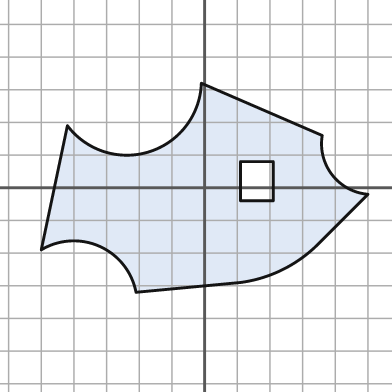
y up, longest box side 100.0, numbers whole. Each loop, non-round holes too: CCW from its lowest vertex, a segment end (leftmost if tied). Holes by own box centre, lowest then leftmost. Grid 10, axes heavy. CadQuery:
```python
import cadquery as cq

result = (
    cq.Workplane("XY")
    .moveTo(-21.0, -32.0)
    .lineTo(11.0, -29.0)
    .threePointArc((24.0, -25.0), (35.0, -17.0))
    .lineTo(50.0, -2.0)
    .threePointArc((39.0, 4.0), (36.0, 16.0))
    .lineTo(-1.0, 32.0)
    .threePointArc((-17.0, 11.0), (-42.0, 19.0))
    .lineTo(-50.0, -19.0)
    .threePointArc((-32.0, -18.0), (-21.0, -32.0))
    .close()
    .moveTo(11.0, -4.0)
    .lineTo(21.0, -4.0)
    .lineTo(21.0, 8.0)
    .lineTo(11.0, 8.0)
    .close()
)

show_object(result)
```